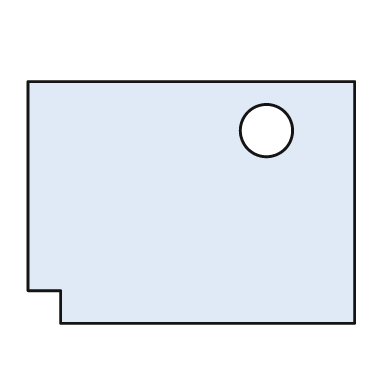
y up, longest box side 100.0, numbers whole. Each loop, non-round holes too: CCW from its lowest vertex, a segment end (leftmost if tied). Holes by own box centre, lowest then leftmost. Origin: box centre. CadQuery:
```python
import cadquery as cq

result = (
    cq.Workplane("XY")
    .moveTo(-40.0, -37.0)
    .lineTo(50.0, -37.0)
    .lineTo(50.0, 37.0)
    .lineTo(-50.0, 37.0)
    .lineTo(-50.0, -27.0)
    .lineTo(-40.0, -27.0)
    .close()
    .moveTo(23.0, 22.0)
    .circle(8.0)
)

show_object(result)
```